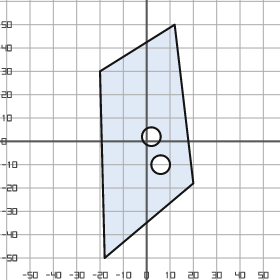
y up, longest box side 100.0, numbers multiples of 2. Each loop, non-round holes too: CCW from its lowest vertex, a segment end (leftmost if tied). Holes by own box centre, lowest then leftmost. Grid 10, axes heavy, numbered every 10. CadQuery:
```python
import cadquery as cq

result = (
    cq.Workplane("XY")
    .moveTo(-18.0, -50.0)
    .lineTo(20.0, -18.0)
    .lineTo(12.0, 50.0)
    .lineTo(-20.0, 30.0)
    .close()
    .moveTo(6.0, -10.0)
    .circle(4.0)
    .moveTo(2.0, 2.0)
    .circle(4.0)
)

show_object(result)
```